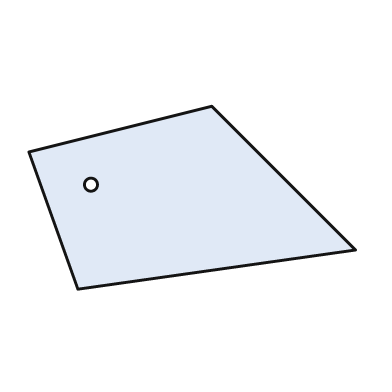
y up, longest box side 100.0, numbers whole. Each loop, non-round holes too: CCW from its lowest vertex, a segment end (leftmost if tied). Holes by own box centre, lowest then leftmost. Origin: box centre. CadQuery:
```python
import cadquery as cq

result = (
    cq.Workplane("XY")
    .moveTo(-35.0, -28.0)
    .lineTo(50.0, -16.0)
    .lineTo(6.0, 28.0)
    .lineTo(-50.0, 14.0)
    .close()
    .moveTo(-31.0, 4.0)
    .circle(2.0)
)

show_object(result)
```